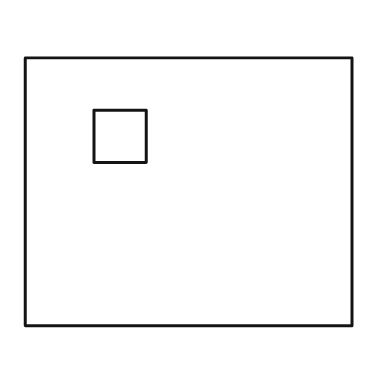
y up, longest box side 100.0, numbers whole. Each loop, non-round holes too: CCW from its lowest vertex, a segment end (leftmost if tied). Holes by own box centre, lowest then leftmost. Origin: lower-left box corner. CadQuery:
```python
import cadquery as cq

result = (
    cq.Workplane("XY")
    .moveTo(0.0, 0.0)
    .lineTo(100.0, 0.0)
    .lineTo(100.0, 82.0)
    .lineTo(0.0, 82.0)
    .close()
    .moveTo(21.0, 50.0)
    .lineTo(37.0, 50.0)
    .lineTo(37.0, 66.0)
    .lineTo(21.0, 66.0)
    .close()
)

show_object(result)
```